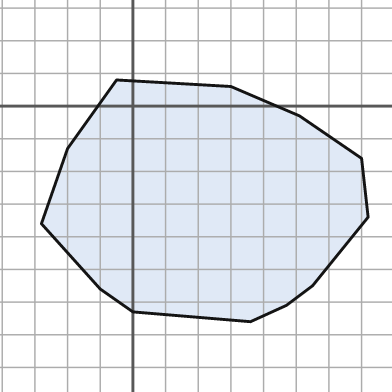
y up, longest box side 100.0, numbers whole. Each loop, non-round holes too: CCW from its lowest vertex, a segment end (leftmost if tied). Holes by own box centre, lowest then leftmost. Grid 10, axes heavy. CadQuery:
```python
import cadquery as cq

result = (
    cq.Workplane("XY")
    .moveTo(36.0, -66.0)
    .lineTo(47.0, -61.0)
    .lineTo(55.0, -55.0)
    .lineTo(72.0, -34.0)
    .lineTo(70.0, -16.0)
    .lineTo(51.0, -3.0)
    .lineTo(30.0, 6.0)
    .lineTo(-5.0, 8.0)
    .lineTo(-20.0, -13.0)
    .lineTo(-28.0, -36.0)
    .lineTo(-10.0, -56.0)
    .lineTo(0.0, -63.0)
    .close()
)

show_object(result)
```